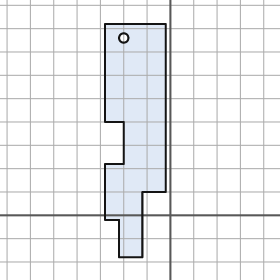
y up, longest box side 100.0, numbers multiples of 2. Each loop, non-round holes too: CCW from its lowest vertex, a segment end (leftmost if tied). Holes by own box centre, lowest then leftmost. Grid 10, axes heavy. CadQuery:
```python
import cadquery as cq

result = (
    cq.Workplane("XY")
    .moveTo(-22.0, -18.0)
    .lineTo(-12.0, -18.0)
    .lineTo(-12.0, 10.0)
    .lineTo(-2.0, 10.0)
    .lineTo(-2.0, 82.0)
    .lineTo(-28.0, 82.0)
    .lineTo(-28.0, 40.0)
    .lineTo(-20.0, 40.0)
    .lineTo(-20.0, 22.0)
    .lineTo(-28.0, 22.0)
    .lineTo(-28.0, -2.0)
    .lineTo(-22.0, -2.0)
    .close()
    .moveTo(-20.0, 76.0)
    .circle(2.0)
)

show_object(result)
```